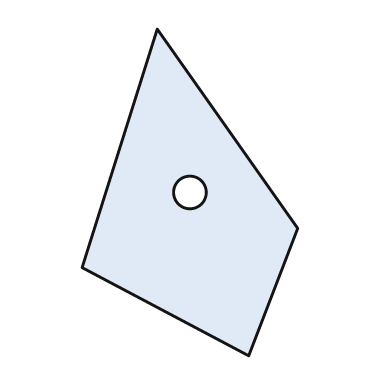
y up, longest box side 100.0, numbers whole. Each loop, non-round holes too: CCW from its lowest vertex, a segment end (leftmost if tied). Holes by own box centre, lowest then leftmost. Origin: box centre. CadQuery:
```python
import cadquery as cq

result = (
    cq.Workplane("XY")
    .moveTo(18.0, -50.0)
    .lineTo(33.0, -11.0)
    .lineTo(-10.0, 50.0)
    .lineTo(-33.0, -23.0)
    .close()
    .moveTo(0.0, 0.0)
    .circle(5.0)
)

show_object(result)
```